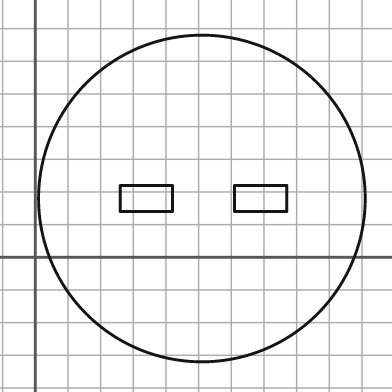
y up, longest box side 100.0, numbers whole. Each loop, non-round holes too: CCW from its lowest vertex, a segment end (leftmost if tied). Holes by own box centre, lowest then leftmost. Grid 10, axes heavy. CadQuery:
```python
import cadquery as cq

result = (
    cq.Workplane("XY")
    .moveTo(51.0, 18.0)
    .circle(50.0)
    .moveTo(26.0, 14.0)
    .lineTo(42.0, 14.0)
    .lineTo(42.0, 22.0)
    .lineTo(26.0, 22.0)
    .close()
    .moveTo(61.0, 14.0)
    .lineTo(77.0, 14.0)
    .lineTo(77.0, 22.0)
    .lineTo(61.0, 22.0)
    .close()
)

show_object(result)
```